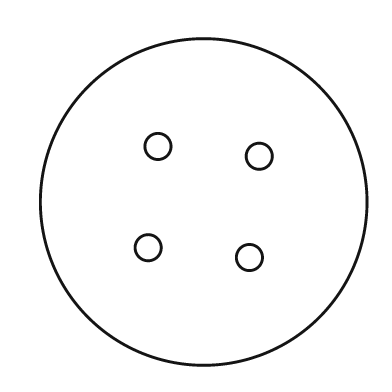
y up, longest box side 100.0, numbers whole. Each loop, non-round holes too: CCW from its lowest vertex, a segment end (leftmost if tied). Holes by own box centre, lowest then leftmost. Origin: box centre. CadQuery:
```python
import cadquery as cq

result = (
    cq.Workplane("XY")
    .moveTo(0.0, 0.0)
    .circle(50.0)
    .moveTo(14.0, -17.0)
    .circle(4.0)
    .moveTo(-17.0, -14.0)
    .circle(4.0)
    .moveTo(17.0, 14.0)
    .circle(4.0)
    .moveTo(-14.0, 17.0)
    .circle(4.0)
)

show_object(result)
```